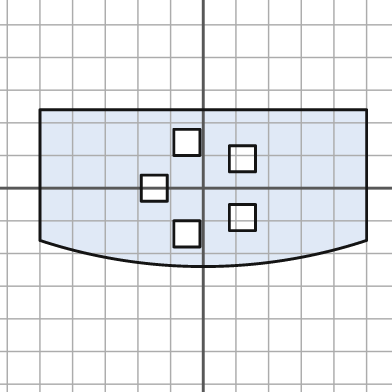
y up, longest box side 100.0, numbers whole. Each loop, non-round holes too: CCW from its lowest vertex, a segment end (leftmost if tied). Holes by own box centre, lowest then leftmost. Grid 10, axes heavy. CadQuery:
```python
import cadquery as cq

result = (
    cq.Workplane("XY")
    .moveTo(-50.0, -16.0)
    .threePointArc((0.0, -24.0), (50.0, -16.0))
    .lineTo(50.0, 24.0)
    .lineTo(-50.0, 24.0)
    .close()
    .moveTo(-9.0, -18.0)
    .lineTo(-1.0, -18.0)
    .lineTo(-1.0, -10.0)
    .lineTo(-9.0, -10.0)
    .close()
    .moveTo(8.0, -13.0)
    .lineTo(16.0, -13.0)
    .lineTo(16.0, -5.0)
    .lineTo(8.0, -5.0)
    .close()
    .moveTo(-19.0, -4.0)
    .lineTo(-11.0, -4.0)
    .lineTo(-11.0, 4.0)
    .lineTo(-19.0, 4.0)
    .close()
    .moveTo(8.0, 5.0)
    .lineTo(16.0, 5.0)
    .lineTo(16.0, 13.0)
    .lineTo(8.0, 13.0)
    .close()
    .moveTo(-9.0, 10.0)
    .lineTo(-1.0, 10.0)
    .lineTo(-1.0, 18.0)
    .lineTo(-9.0, 18.0)
    .close()
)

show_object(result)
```